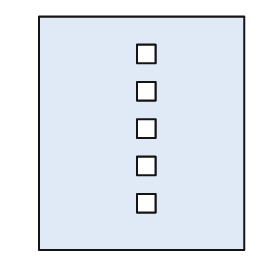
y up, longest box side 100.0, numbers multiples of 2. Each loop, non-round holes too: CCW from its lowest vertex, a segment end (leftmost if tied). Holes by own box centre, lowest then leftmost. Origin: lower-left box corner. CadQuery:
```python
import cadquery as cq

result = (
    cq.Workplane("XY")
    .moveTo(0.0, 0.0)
    .lineTo(88.0, 0.0)
    .lineTo(88.0, 100.0)
    .lineTo(0.0, 100.0)
    .close()
    .moveTo(42.0, 16.0)
    .lineTo(50.0, 16.0)
    .lineTo(50.0, 24.0)
    .lineTo(42.0, 24.0)
    .close()
    .moveTo(42.0, 32.0)
    .lineTo(50.0, 32.0)
    .lineTo(50.0, 40.0)
    .lineTo(42.0, 40.0)
    .close()
    .moveTo(42.0, 48.0)
    .lineTo(50.0, 48.0)
    .lineTo(50.0, 56.0)
    .lineTo(42.0, 56.0)
    .close()
    .moveTo(42.0, 64.0)
    .lineTo(50.0, 64.0)
    .lineTo(50.0, 72.0)
    .lineTo(42.0, 72.0)
    .close()
    .moveTo(42.0, 80.0)
    .lineTo(50.0, 80.0)
    .lineTo(50.0, 88.0)
    .lineTo(42.0, 88.0)
    .close()
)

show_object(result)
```